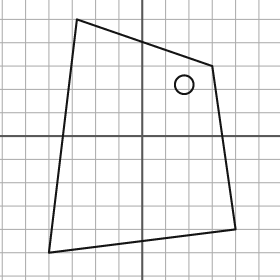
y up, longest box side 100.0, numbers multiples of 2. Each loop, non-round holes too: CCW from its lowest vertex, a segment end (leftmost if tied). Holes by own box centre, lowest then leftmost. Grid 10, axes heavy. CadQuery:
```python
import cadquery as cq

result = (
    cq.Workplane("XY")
    .moveTo(-40.0, -50.0)
    .lineTo(40.0, -40.0)
    .lineTo(30.0, 30.0)
    .lineTo(-28.0, 50.0)
    .close()
    .moveTo(18.0, 22.0)
    .circle(4.0)
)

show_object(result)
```